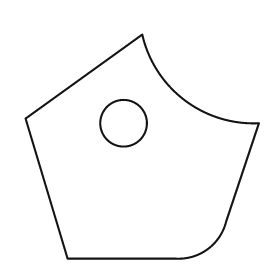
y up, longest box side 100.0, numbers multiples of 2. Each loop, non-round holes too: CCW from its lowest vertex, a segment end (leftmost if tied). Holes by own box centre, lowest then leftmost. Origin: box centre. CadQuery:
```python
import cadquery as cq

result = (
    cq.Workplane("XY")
    .moveTo(-32.0, -48.0)
    .lineTo(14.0, -48.0)
    .threePointArc((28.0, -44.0), (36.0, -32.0))
    .lineTo(50.0, 10.0)
    .threePointArc((18.0, 20.0), (0.0, 48.0))
    .lineTo(-50.0, 12.0)
    .close()
    .moveTo(-8.0, 10.0)
    .circle(10.0)
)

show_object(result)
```